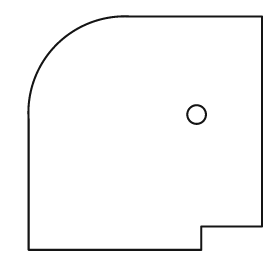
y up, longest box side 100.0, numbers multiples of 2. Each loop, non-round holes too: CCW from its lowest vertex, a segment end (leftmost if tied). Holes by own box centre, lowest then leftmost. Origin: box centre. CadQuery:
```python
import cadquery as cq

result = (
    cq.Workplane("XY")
    .moveTo(-50.0, -50.0)
    .lineTo(24.0, -50.0)
    .lineTo(24.0, -40.0)
    .lineTo(50.0, -40.0)
    .lineTo(50.0, 50.0)
    .lineTo(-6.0, 50.0)
    .threePointArc((-38.0, 38.0), (-50.0, 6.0))
    .close()
    .moveTo(22.0, 8.0)
    .circle(4.0)
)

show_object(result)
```